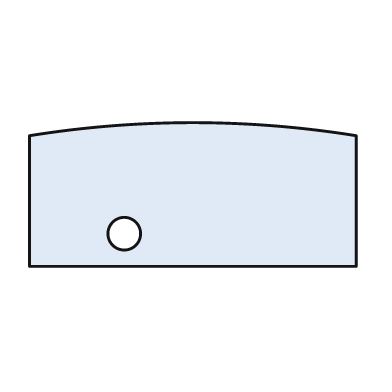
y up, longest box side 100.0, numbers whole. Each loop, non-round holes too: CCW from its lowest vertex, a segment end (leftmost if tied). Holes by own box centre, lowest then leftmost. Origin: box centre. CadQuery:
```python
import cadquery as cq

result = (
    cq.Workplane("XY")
    .moveTo(-50.0, -22.0)
    .lineTo(50.0, -22.0)
    .lineTo(50.0, 18.0)
    .threePointArc((0.0, 22.0), (-50.0, 18.0))
    .close()
    .moveTo(-21.0, -12.0)
    .circle(5.0)
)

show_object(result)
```